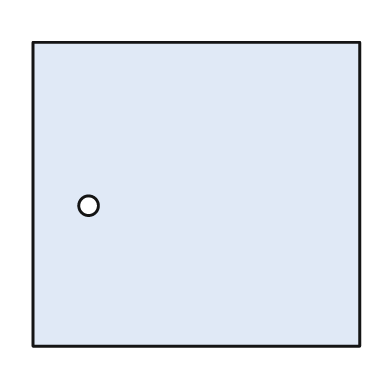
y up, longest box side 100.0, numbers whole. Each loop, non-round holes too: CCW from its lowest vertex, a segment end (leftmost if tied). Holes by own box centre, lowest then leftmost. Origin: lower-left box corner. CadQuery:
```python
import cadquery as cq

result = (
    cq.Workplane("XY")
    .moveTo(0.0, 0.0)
    .lineTo(100.0, 0.0)
    .lineTo(100.0, 93.0)
    .lineTo(0.0, 93.0)
    .close()
    .moveTo(17.0, 43.0)
    .circle(3.0)
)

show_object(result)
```